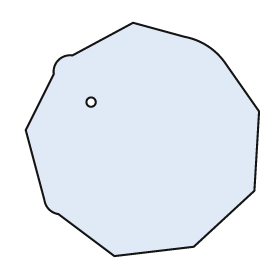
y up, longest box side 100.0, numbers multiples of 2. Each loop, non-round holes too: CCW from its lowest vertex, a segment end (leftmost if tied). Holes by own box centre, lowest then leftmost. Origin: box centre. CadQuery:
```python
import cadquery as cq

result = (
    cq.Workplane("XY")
    .moveTo(-12.0, -50.0)
    .lineTo(22.0, -46.0)
    .lineTo(48.0, -22.0)
    .lineTo(50.0, 12.0)
    .lineTo(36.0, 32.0)
    .threePointArc((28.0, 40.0), (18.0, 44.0))
    .lineTo(-4.0, 50.0)
    .lineTo(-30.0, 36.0)
    .threePointArc((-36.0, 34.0), (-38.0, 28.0))
    .lineTo(-50.0, 4.0)
    .lineTo(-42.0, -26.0)
    .threePointArc((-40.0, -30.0), (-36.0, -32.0))
    .close()
    .moveTo(-22.0, 16.0)
    .circle(2.0)
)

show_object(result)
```